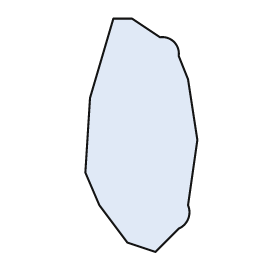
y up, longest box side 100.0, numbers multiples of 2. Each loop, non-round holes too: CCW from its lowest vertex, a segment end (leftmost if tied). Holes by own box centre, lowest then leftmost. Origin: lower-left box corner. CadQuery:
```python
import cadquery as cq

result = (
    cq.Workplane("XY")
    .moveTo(30.0, 0.0)
    .lineTo(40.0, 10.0)
    .threePointArc((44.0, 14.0), (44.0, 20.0))
    .lineTo(48.0, 48.0)
    .lineTo(44.0, 74.0)
    .lineTo(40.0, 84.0)
    .threePointArc((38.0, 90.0), (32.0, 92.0))
    .lineTo(20.0, 100.0)
    .lineTo(12.0, 100.0)
    .lineTo(2.0, 66.0)
    .lineTo(0.0, 34.0)
    .lineTo(6.0, 20.0)
    .lineTo(18.0, 4.0)
    .close()
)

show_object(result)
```